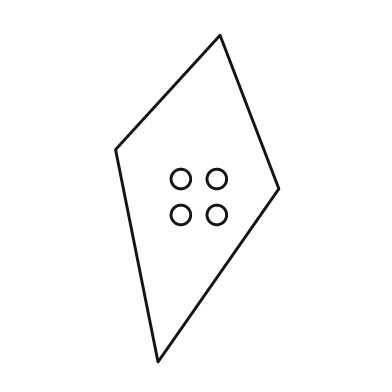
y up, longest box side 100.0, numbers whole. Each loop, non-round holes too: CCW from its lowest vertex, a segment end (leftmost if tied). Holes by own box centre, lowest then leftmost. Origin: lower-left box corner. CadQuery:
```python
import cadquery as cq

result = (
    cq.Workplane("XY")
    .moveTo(13.0, 0.0)
    .lineTo(50.0, 53.0)
    .lineTo(32.0, 100.0)
    .lineTo(0.0, 65.0)
    .close()
    .moveTo(20.0, 45.0)
    .circle(3.0)
    .moveTo(31.0, 45.0)
    .circle(3.0)
    .moveTo(20.0, 56.0)
    .circle(3.0)
    .moveTo(31.0, 56.0)
    .circle(3.0)
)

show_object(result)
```